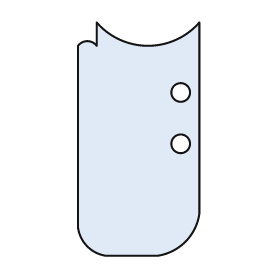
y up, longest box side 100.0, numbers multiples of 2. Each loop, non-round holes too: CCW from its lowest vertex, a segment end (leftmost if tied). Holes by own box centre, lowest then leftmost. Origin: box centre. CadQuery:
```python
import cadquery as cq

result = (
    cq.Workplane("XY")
    .moveTo(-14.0, -50.0)
    .lineTo(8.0, -50.0)
    .threePointArc((20.0, -44.0), (26.0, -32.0))
    .lineTo(26.0, 50.0)
    .threePointArc((4.0, 40.0), (-18.0, 50.0))
    .lineTo(-18.0, 40.0)
    .threePointArc((-22.0, 42.0), (-26.0, 40.0))
    .lineTo(-26.0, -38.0)
    .threePointArc((-22.0, -46.0), (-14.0, -50.0))
    .close()
    .moveTo(18.0, -2.0)
    .circle(4.0)
    .moveTo(18.0, 20.0)
    .circle(4.0)
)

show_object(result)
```